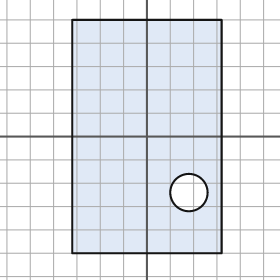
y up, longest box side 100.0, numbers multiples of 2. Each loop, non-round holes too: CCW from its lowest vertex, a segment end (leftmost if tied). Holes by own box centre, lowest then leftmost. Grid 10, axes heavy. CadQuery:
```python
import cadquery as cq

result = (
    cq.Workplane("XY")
    .moveTo(-32.0, -50.0)
    .lineTo(32.0, -50.0)
    .lineTo(32.0, 50.0)
    .lineTo(-32.0, 50.0)
    .close()
    .moveTo(18.0, -24.0)
    .circle(8.0)
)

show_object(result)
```